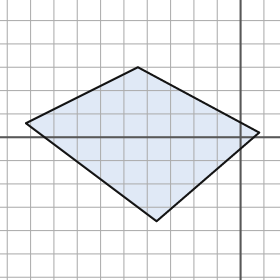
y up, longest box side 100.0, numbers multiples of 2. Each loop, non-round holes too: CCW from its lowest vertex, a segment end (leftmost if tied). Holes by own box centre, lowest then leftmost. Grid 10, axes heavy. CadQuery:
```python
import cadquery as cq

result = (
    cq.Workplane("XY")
    .moveTo(-36.0, -36.0)
    .lineTo(8.0, 2.0)
    .lineTo(-44.0, 30.0)
    .lineTo(-92.0, 6.0)
    .close()
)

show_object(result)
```